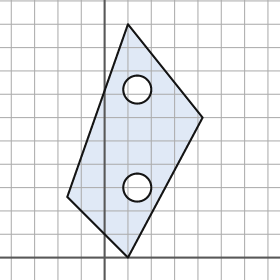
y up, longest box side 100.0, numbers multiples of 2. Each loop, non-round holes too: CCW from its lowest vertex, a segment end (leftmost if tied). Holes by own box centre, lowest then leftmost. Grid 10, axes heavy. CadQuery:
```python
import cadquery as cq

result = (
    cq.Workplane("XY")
    .moveTo(10.0, 0.0)
    .lineTo(42.0, 60.0)
    .lineTo(10.0, 100.0)
    .lineTo(-16.0, 26.0)
    .close()
    .moveTo(14.0, 30.0)
    .circle(6.0)
    .moveTo(14.0, 72.0)
    .circle(6.0)
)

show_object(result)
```